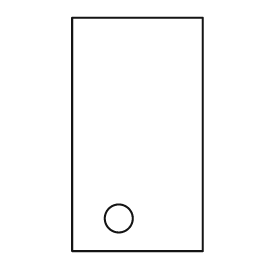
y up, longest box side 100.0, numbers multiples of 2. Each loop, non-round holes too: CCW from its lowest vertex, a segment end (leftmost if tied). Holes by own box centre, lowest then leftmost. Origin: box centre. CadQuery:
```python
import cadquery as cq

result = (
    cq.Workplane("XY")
    .moveTo(-28.0, -50.0)
    .lineTo(28.0, -50.0)
    .lineTo(28.0, 50.0)
    .lineTo(-28.0, 50.0)
    .close()
    .moveTo(-8.0, -36.0)
    .circle(6.0)
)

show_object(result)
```